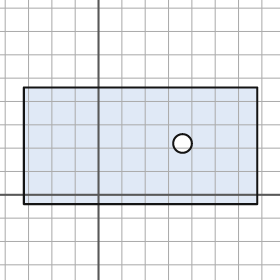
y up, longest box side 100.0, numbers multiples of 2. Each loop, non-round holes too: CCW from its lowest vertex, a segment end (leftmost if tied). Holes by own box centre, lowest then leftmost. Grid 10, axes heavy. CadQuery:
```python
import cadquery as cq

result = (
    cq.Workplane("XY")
    .moveTo(-32.0, -4.0)
    .lineTo(68.0, -4.0)
    .lineTo(68.0, 46.0)
    .lineTo(-32.0, 46.0)
    .close()
    .moveTo(36.0, 22.0)
    .circle(4.0)
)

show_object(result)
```